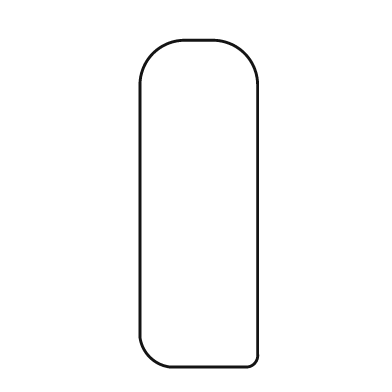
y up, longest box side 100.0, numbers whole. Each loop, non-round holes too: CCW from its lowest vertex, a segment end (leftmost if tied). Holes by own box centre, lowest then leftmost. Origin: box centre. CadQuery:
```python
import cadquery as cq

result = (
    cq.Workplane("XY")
    .moveTo(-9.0, -50.0)
    .lineTo(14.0, -50.0)
    .threePointArc((17.0, -49.0), (18.0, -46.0))
    .lineTo(18.0, 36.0)
    .threePointArc((14.0, 46.0), (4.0, 50.0))
    .lineTo(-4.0, 50.0)
    .threePointArc((-14.0, 46.0), (-18.0, 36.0))
    .lineTo(-18.0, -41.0)
    .threePointArc((-15.0, -47.0), (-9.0, -50.0))
    .close()
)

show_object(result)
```